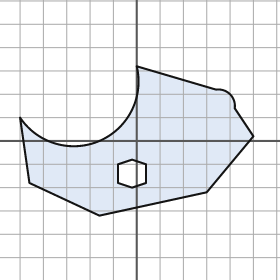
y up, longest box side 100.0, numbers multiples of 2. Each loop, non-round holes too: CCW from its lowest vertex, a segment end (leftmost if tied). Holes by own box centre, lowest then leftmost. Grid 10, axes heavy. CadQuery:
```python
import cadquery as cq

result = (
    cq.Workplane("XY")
    .moveTo(-16.0, -32.0)
    .lineTo(30.0, -22.0)
    .lineTo(50.0, 2.0)
    .lineTo(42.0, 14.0)
    .threePointArc((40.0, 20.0), (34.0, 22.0))
    .lineTo(0.0, 32.0)
    .threePointArc((-16.0, 0.0), (-50.0, 10.0))
    .lineTo(-46.0, -18.0)
    .close()
    .moveTo(-2.0, -20.0)
    .lineTo(4.0, -18.0)
    .lineTo(4.0, -10.0)
    .lineTo(-2.0, -8.0)
    .lineTo(-8.0, -10.0)
    .lineTo(-8.0, -18.0)
    .close()
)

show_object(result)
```